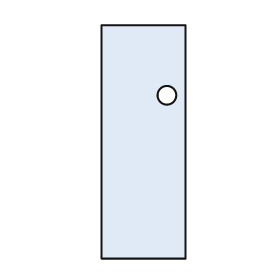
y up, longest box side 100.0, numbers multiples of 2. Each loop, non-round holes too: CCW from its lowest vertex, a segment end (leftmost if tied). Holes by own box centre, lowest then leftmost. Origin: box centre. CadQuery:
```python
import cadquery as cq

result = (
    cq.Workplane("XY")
    .moveTo(-18.0, -50.0)
    .lineTo(18.0, -50.0)
    .lineTo(18.0, 50.0)
    .lineTo(-18.0, 50.0)
    .close()
    .moveTo(10.0, 20.0)
    .circle(4.0)
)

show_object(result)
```